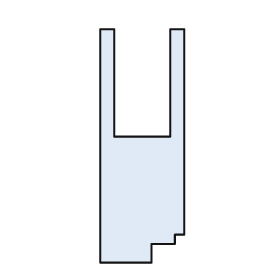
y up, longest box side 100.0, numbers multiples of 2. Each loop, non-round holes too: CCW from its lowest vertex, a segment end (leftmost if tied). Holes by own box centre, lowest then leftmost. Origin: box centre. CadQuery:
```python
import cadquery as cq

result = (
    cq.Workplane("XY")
    .moveTo(-18.0, -50.0)
    .lineTo(4.0, -50.0)
    .lineTo(4.0, -42.0)
    .lineTo(14.0, -42.0)
    .lineTo(14.0, -38.0)
    .lineTo(18.0, -38.0)
    .lineTo(18.0, 50.0)
    .lineTo(12.0, 50.0)
    .lineTo(12.0, 4.0)
    .lineTo(-12.0, 4.0)
    .lineTo(-12.0, 50.0)
    .lineTo(-18.0, 50.0)
    .close()
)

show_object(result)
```